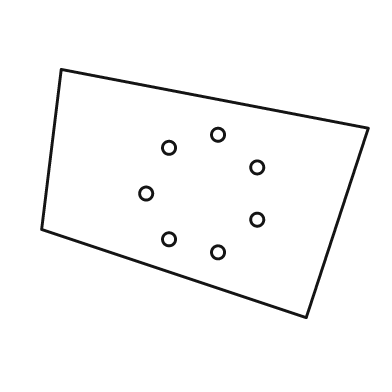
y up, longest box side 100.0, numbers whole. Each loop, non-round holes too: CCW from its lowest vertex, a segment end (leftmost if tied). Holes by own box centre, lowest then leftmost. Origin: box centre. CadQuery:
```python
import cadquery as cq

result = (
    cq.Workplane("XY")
    .moveTo(31.0, -38.0)
    .lineTo(50.0, 20.0)
    .lineTo(-44.0, 38.0)
    .lineTo(-50.0, -11.0)
    .close()
    .moveTo(4.0, -18.0)
    .circle(2.0)
    .moveTo(-11.0, -14.0)
    .circle(2.0)
    .moveTo(16.0, -8.0)
    .circle(2.0)
    .moveTo(-18.0, 0.0)
    .circle(2.0)
    .moveTo(16.0, 8.0)
    .circle(2.0)
    .moveTo(-11.0, 14.0)
    .circle(2.0)
    .moveTo(4.0, 18.0)
    .circle(2.0)
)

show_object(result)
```